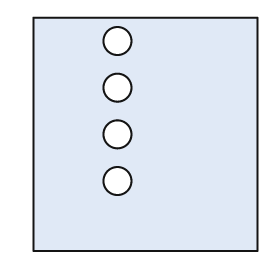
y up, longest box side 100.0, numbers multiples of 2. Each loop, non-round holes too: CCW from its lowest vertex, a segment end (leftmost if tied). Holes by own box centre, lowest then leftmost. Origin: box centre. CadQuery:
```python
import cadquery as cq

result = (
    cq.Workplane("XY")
    .moveTo(-48.0, -50.0)
    .lineTo(48.0, -50.0)
    .lineTo(48.0, 50.0)
    .lineTo(-48.0, 50.0)
    .close()
    .moveTo(-12.0, -20.0)
    .circle(6.0)
    .moveTo(-12.0, 0.0)
    .circle(6.0)
    .moveTo(-12.0, 20.0)
    .circle(6.0)
    .moveTo(-12.0, 40.0)
    .circle(6.0)
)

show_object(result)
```